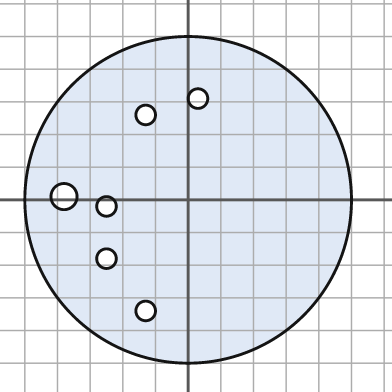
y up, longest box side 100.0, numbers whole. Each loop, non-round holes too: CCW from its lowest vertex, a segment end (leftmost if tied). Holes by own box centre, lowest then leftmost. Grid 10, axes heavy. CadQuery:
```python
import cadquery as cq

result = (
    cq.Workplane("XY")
    .moveTo(0.0, 0.0)
    .circle(50.0)
    .moveTo(-13.0, -34.0)
    .circle(3.0)
    .moveTo(-25.0, -18.0)
    .circle(3.0)
    .moveTo(-25.0, -2.0)
    .circle(3.0)
    .moveTo(-38.0, 1.0)
    .circle(4.0)
    .moveTo(-13.0, 26.0)
    .circle(3.0)
    .moveTo(3.0, 31.0)
    .circle(3.0)
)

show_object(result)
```